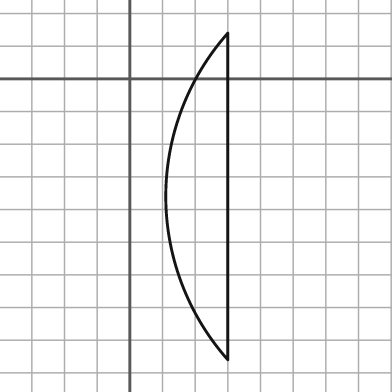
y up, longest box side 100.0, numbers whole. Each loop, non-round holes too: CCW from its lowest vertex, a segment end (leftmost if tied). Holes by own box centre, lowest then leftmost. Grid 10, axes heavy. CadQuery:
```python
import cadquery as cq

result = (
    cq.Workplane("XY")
    .moveTo(30.0, -86.0)
    .lineTo(30.0, 14.0)
    .threePointArc((11.0, -36.0), (30.0, -86.0))
    .close()
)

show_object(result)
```